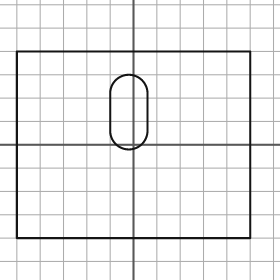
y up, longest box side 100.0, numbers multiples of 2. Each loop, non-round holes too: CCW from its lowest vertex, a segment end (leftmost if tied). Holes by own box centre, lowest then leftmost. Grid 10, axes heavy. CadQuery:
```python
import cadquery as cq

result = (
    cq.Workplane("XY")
    .moveTo(-50.0, -40.0)
    .lineTo(50.0, -40.0)
    .lineTo(50.0, 40.0)
    .lineTo(-50.0, 40.0)
    .close()
    .moveTo(-10.0, 6.0)
    .threePointArc((-2.0, -2.0), (6.0, 6.0))
    .lineTo(6.0, 22.0)
    .threePointArc((-2.0, 30.0), (-10.0, 22.0))
    .close()
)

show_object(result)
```